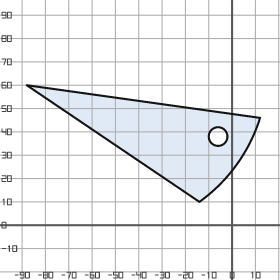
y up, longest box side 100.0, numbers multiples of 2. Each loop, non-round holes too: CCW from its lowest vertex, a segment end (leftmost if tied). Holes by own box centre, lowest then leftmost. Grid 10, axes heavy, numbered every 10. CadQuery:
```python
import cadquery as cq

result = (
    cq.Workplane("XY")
    .moveTo(-14.0, 10.0)
    .threePointArc((2.0, 26.0), (12.0, 46.0))
    .lineTo(-88.0, 60.0)
    .close()
    .moveTo(-6.0, 38.0)
    .circle(4.0)
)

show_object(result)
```